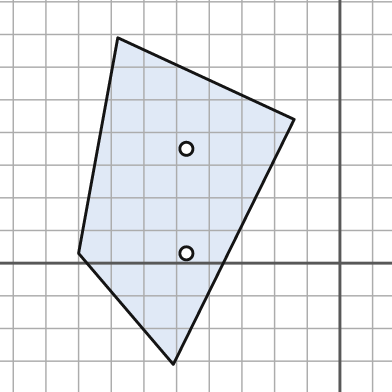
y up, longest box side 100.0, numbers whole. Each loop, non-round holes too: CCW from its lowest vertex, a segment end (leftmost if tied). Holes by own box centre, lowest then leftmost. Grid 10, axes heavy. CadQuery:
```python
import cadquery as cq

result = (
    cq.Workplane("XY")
    .moveTo(-51.0, -31.0)
    .lineTo(-14.0, 44.0)
    .lineTo(-68.0, 69.0)
    .lineTo(-80.0, 3.0)
    .close()
    .moveTo(-47.0, 3.0)
    .circle(2.0)
    .moveTo(-47.0, 35.0)
    .circle(2.0)
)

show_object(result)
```